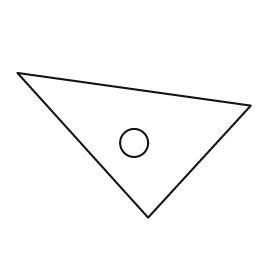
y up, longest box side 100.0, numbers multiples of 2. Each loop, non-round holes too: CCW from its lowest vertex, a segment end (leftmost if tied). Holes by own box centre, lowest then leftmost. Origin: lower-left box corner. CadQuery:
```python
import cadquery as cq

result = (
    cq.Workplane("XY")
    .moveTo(56.0, 0.0)
    .lineTo(100.0, 48.0)
    .lineTo(0.0, 62.0)
    .close()
    .moveTo(50.0, 32.0)
    .circle(6.0)
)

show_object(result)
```